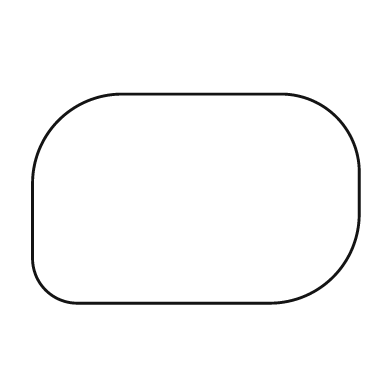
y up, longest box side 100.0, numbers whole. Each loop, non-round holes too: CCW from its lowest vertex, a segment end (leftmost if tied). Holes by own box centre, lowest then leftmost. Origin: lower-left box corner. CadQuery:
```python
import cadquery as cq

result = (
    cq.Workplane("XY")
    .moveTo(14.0, 0.0)
    .lineTo(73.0, 0.0)
    .threePointArc((92.0, 8.0), (100.0, 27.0))
    .lineTo(100.0, 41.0)
    .threePointArc((93.0, 57.0), (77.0, 64.0))
    .lineTo(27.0, 64.0)
    .threePointArc((8.0, 56.0), (0.0, 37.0))
    .lineTo(0.0, 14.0)
    .threePointArc((4.0, 4.0), (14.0, 0.0))
    .close()
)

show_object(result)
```